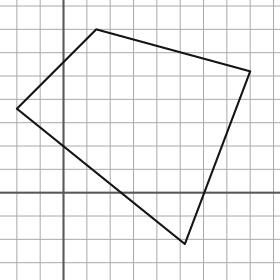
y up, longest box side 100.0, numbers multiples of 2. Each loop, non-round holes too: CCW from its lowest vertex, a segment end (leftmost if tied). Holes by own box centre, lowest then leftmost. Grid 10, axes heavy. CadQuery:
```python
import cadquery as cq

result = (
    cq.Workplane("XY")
    .moveTo(52.0, -22.0)
    .lineTo(80.0, 52.0)
    .lineTo(14.0, 70.0)
    .lineTo(-20.0, 36.0)
    .close()
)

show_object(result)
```